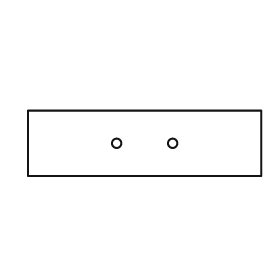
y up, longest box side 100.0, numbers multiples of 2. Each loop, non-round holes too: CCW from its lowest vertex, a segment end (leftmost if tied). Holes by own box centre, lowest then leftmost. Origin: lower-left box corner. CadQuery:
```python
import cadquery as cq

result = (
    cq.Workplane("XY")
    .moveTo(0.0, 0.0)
    .lineTo(100.0, 0.0)
    .lineTo(100.0, 28.0)
    .lineTo(0.0, 28.0)
    .close()
    .moveTo(38.0, 14.0)
    .circle(2.0)
    .moveTo(62.0, 14.0)
    .circle(2.0)
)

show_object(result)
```